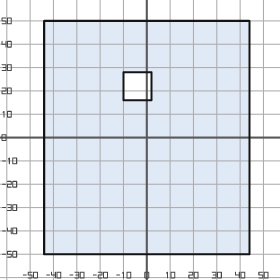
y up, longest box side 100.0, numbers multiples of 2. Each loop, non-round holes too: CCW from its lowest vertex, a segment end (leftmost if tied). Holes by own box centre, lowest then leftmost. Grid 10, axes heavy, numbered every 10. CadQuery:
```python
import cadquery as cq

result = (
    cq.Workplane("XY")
    .moveTo(-44.0, -50.0)
    .lineTo(44.0, -50.0)
    .lineTo(44.0, 50.0)
    .lineTo(-44.0, 50.0)
    .close()
    .moveTo(-10.0, 16.0)
    .lineTo(2.0, 16.0)
    .lineTo(2.0, 28.0)
    .lineTo(-10.0, 28.0)
    .close()
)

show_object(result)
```